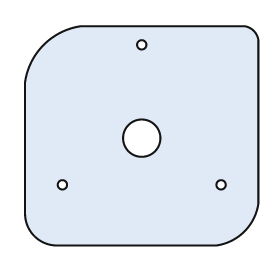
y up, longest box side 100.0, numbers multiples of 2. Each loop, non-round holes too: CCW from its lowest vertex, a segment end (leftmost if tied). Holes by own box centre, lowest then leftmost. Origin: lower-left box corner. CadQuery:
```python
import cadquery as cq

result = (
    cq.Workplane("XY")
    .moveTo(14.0, 0.0)
    .lineTo(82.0, 0.0)
    .threePointArc((94.0, 6.0), (100.0, 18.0))
    .lineTo(100.0, 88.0)
    .threePointArc((98.0, 92.0), (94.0, 94.0))
    .lineTo(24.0, 94.0)
    .threePointArc((8.0, 86.0), (0.0, 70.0))
    .lineTo(0.0, 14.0)
    .threePointArc((4.0, 4.0), (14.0, 0.0))
    .close()
    .moveTo(16.0, 26.0)
    .circle(2.0)
    .moveTo(84.0, 26.0)
    .circle(2.0)
    .moveTo(50.0, 46.0)
    .circle(8.0)
    .moveTo(50.0, 86.0)
    .circle(2.0)
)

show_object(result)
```